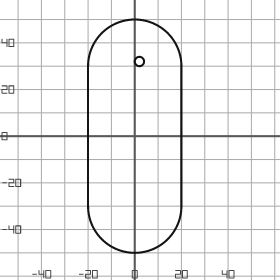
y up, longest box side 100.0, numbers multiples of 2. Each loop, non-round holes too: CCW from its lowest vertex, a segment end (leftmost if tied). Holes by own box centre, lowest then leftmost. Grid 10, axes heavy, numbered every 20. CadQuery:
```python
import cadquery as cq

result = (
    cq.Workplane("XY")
    .moveTo(-20.0, -30.0)
    .threePointArc((0.0, -50.0), (20.0, -30.0))
    .lineTo(20.0, 30.0)
    .threePointArc((0.0, 50.0), (-20.0, 30.0))
    .close()
    .moveTo(2.0, 32.0)
    .circle(2.0)
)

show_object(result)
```